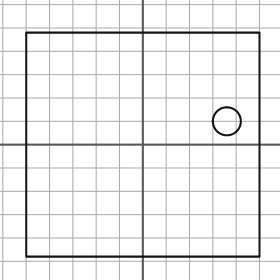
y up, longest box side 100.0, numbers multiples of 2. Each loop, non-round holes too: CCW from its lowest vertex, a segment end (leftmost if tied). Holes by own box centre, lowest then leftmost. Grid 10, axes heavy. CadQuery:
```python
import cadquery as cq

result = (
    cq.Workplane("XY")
    .moveTo(-50.0, -48.0)
    .lineTo(50.0, -48.0)
    .lineTo(50.0, 48.0)
    .lineTo(-50.0, 48.0)
    .close()
    .moveTo(36.0, 10.0)
    .circle(6.0)
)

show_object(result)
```